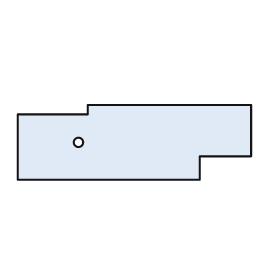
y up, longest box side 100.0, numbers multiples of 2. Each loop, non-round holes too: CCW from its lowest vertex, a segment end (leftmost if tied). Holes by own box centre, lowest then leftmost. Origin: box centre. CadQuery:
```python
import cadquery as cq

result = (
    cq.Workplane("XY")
    .moveTo(-50.0, -16.0)
    .lineTo(28.0, -16.0)
    .lineTo(28.0, -6.0)
    .lineTo(50.0, -6.0)
    .lineTo(50.0, 16.0)
    .lineTo(-20.0, 16.0)
    .lineTo(-20.0, 12.0)
    .lineTo(-50.0, 12.0)
    .close()
    .moveTo(-24.0, 0.0)
    .circle(2.0)
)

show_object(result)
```